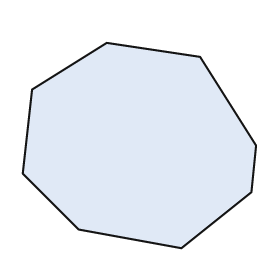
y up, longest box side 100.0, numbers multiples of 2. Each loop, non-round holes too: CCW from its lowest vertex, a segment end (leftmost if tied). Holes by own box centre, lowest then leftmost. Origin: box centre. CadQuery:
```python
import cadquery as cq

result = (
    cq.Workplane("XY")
    .moveTo(18.0, -44.0)
    .lineTo(48.0, -20.0)
    .lineTo(50.0, 0.0)
    .lineTo(26.0, 38.0)
    .lineTo(-14.0, 44.0)
    .lineTo(-46.0, 24.0)
    .lineTo(-50.0, -12.0)
    .lineTo(-26.0, -36.0)
    .close()
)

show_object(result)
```